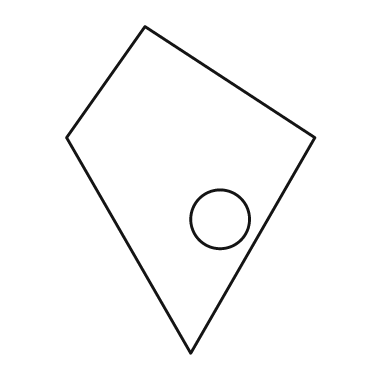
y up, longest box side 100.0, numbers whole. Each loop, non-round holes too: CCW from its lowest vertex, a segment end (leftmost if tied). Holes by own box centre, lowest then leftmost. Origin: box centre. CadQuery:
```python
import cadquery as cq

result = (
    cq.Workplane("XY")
    .moveTo(0.0, -50.0)
    .lineTo(38.0, 16.0)
    .lineTo(-14.0, 50.0)
    .lineTo(-38.0, 16.0)
    .close()
    .moveTo(9.0, -9.0)
    .circle(9.0)
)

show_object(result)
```